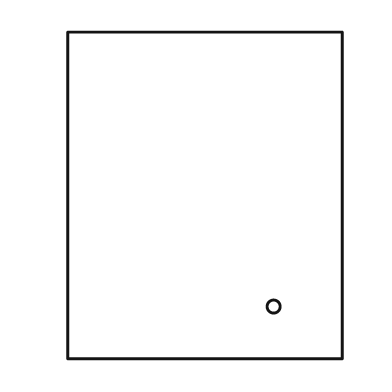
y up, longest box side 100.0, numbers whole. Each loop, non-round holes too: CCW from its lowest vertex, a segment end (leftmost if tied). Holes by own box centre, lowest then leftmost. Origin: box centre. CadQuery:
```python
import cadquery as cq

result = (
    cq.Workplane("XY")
    .moveTo(-42.0, -50.0)
    .lineTo(42.0, -50.0)
    .lineTo(42.0, 50.0)
    .lineTo(-42.0, 50.0)
    .close()
    .moveTo(21.0, -34.0)
    .circle(2.0)
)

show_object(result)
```